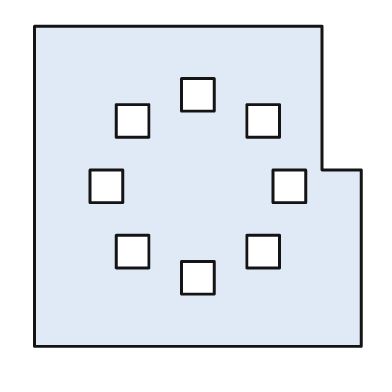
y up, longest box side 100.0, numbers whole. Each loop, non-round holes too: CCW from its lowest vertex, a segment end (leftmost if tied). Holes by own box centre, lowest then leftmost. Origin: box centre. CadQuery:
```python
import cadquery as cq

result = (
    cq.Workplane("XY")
    .moveTo(-50.0, -49.0)
    .lineTo(50.0, -49.0)
    .lineTo(50.0, 5.0)
    .lineTo(38.0, 5.0)
    .lineTo(38.0, 49.0)
    .lineTo(-50.0, 49.0)
    .close()
    .moveTo(-5.0, -33.0)
    .lineTo(5.0, -33.0)
    .lineTo(5.0, -23.0)
    .lineTo(-5.0, -23.0)
    .close()
    .moveTo(-25.0, -25.0)
    .lineTo(-15.0, -25.0)
    .lineTo(-15.0, -15.0)
    .lineTo(-25.0, -15.0)
    .close()
    .moveTo(15.0, -25.0)
    .lineTo(25.0, -25.0)
    .lineTo(25.0, -15.0)
    .lineTo(15.0, -15.0)
    .close()
    .moveTo(-33.0, -5.0)
    .lineTo(-23.0, -5.0)
    .lineTo(-23.0, 5.0)
    .lineTo(-33.0, 5.0)
    .close()
    .moveTo(23.0, -5.0)
    .lineTo(33.0, -5.0)
    .lineTo(33.0, 5.0)
    .lineTo(23.0, 5.0)
    .close()
    .moveTo(-25.0, 15.0)
    .lineTo(-15.0, 15.0)
    .lineTo(-15.0, 25.0)
    .lineTo(-25.0, 25.0)
    .close()
    .moveTo(15.0, 15.0)
    .lineTo(25.0, 15.0)
    .lineTo(25.0, 25.0)
    .lineTo(15.0, 25.0)
    .close()
    .moveTo(-5.0, 23.0)
    .lineTo(5.0, 23.0)
    .lineTo(5.0, 33.0)
    .lineTo(-5.0, 33.0)
    .close()
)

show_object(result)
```